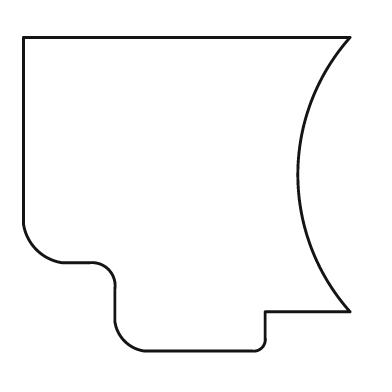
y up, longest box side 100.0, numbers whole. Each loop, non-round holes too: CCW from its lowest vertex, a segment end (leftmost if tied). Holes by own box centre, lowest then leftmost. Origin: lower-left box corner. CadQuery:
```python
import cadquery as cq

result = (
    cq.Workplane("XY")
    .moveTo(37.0, 0.0)
    .lineTo(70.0, 0.0)
    .threePointArc((73.0, 1.0), (74.0, 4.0))
    .lineTo(74.0, 12.0)
    .lineTo(100.0, 12.0)
    .threePointArc((84.0, 54.0), (100.0, 96.0))
    .lineTo(0.0, 96.0)
    .lineTo(0.0, 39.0)
    .threePointArc((4.0, 31.0), (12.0, 27.0))
    .lineTo(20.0, 27.0)
    .threePointArc((26.0, 25.0), (28.0, 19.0))
    .lineTo(28.0, 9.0)
    .threePointArc((31.0, 3.0), (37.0, 0.0))
    .close()
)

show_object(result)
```